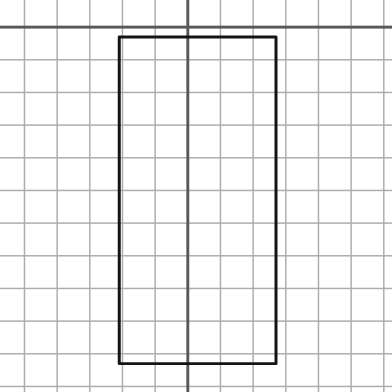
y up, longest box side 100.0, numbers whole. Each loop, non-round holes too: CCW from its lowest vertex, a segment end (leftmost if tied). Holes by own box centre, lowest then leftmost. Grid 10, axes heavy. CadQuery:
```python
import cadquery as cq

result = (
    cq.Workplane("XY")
    .moveTo(-21.0, -103.0)
    .lineTo(27.0, -103.0)
    .lineTo(27.0, -3.0)
    .lineTo(-21.0, -3.0)
    .close()
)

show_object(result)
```